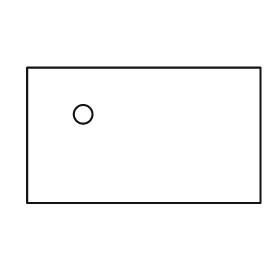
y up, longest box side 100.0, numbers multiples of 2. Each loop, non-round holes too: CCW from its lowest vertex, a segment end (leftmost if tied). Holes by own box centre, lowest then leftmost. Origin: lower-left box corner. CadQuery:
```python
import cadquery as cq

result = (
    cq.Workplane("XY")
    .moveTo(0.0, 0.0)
    .lineTo(100.0, 0.0)
    .lineTo(100.0, 58.0)
    .lineTo(0.0, 58.0)
    .close()
    .moveTo(24.0, 38.0)
    .circle(4.0)
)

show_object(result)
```